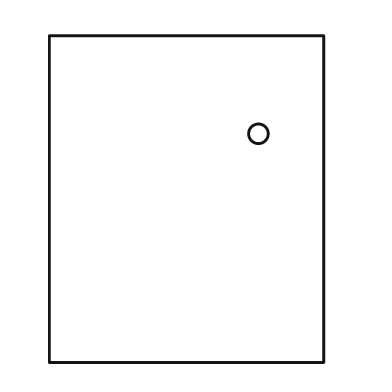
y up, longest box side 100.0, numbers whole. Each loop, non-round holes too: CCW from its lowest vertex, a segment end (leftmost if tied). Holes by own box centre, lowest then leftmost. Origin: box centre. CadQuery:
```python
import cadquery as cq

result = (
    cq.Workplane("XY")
    .moveTo(-42.0, -50.0)
    .lineTo(42.0, -50.0)
    .lineTo(42.0, 50.0)
    .lineTo(-42.0, 50.0)
    .close()
    .moveTo(22.0, 20.0)
    .circle(3.0)
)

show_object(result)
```